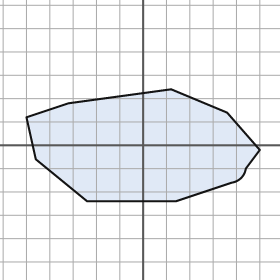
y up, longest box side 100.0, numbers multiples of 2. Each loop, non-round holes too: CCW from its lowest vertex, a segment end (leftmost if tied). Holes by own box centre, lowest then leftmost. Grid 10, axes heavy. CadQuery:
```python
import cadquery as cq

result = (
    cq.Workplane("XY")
    .moveTo(-24.0, -24.0)
    .lineTo(14.0, -24.0)
    .lineTo(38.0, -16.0)
    .threePointArc((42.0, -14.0), (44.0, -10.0))
    .lineTo(50.0, -2.0)
    .lineTo(36.0, 14.0)
    .lineTo(12.0, 24.0)
    .lineTo(-32.0, 18.0)
    .lineTo(-50.0, 12.0)
    .lineTo(-46.0, -6.0)
    .close()
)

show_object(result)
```